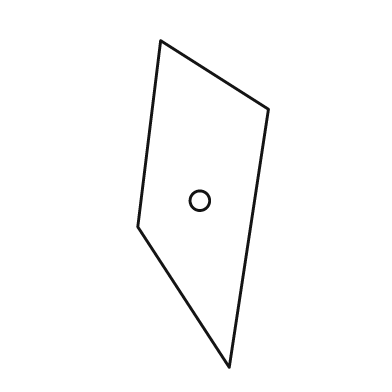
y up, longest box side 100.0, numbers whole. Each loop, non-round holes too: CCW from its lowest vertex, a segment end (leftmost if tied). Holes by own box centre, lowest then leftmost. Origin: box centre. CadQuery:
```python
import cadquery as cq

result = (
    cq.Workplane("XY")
    .moveTo(8.0, -50.0)
    .lineTo(20.0, 29.0)
    .lineTo(-13.0, 50.0)
    .lineTo(-20.0, -7.0)
    .close()
    .moveTo(-1.0, 1.0)
    .circle(3.0)
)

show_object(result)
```